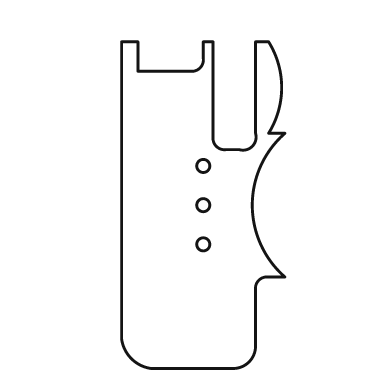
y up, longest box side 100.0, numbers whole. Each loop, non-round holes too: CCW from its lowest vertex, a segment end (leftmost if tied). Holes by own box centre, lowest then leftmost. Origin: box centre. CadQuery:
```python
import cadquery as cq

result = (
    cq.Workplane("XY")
    .moveTo(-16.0, -50.0)
    .lineTo(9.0, -50.0)
    .threePointArc((14.0, -48.0), (16.0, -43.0))
    .lineTo(16.0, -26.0)
    .threePointArc((17.0, -23.0), (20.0, -22.0))
    .lineTo(25.0, -22.0)
    .threePointArc((15.0, 0.0), (25.0, 22.0))
    .lineTo(20.0, 22.0)
    .threePointArc((24.0, 36.0), (20.0, 50.0))
    .lineTo(16.0, 50.0)
    .lineTo(16.0, 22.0)
    .threePointArc((15.0, 18.0), (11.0, 17.0))
    .lineTo(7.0, 17.0)
    .threePointArc((4.0, 18.0), (3.0, 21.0))
    .lineTo(3.0, 50.0)
    .lineTo(0.0, 50.0)
    .lineTo(0.0, 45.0)
    .threePointArc((-1.0, 42.0), (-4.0, 41.0))
    .lineTo(-20.0, 41.0)
    .lineTo(-20.0, 50.0)
    .lineTo(-25.0, 50.0)
    .lineTo(-25.0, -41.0)
    .threePointArc((-22.0, -47.0), (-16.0, -50.0))
    .close()
    .moveTo(0.0, -12.0)
    .circle(2.0)
    .moveTo(0.0, 0.0)
    .circle(2.0)
    .moveTo(0.0, 12.0)
    .circle(2.0)
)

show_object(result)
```